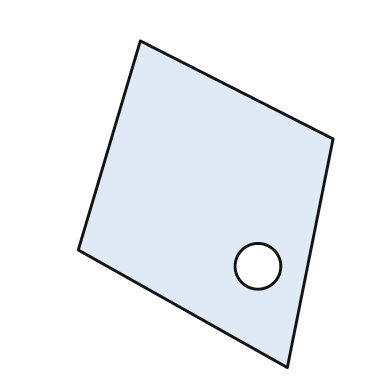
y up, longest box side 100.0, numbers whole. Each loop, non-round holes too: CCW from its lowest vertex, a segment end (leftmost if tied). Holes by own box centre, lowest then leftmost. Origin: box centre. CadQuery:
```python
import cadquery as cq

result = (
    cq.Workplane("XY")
    .moveTo(25.0, -50.0)
    .lineTo(39.0, 20.0)
    .lineTo(-20.0, 50.0)
    .lineTo(-39.0, -14.0)
    .close()
    .moveTo(16.0, -19.0)
    .circle(7.0)
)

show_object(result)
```